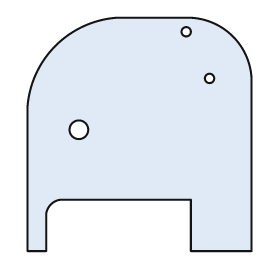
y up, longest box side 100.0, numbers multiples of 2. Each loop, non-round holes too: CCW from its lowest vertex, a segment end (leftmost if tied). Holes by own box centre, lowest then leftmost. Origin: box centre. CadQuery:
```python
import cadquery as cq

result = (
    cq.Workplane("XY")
    .moveTo(-48.0, -50.0)
    .lineTo(-40.0, -50.0)
    .lineTo(-40.0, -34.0)
    .threePointArc((-38.0, -30.0), (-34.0, -28.0))
    .lineTo(22.0, -28.0)
    .lineTo(22.0, -50.0)
    .lineTo(48.0, -50.0)
    .lineTo(48.0, 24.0)
    .threePointArc((40.0, 42.0), (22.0, 50.0))
    .lineTo(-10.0, 50.0)
    .threePointArc((-36.0, 38.0), (-48.0, 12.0))
    .close()
    .moveTo(-26.0, 2.0)
    .circle(4.0)
    .moveTo(30.0, 24.0)
    .circle(2.0)
    .moveTo(20.0, 44.0)
    .circle(2.0)
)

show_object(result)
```